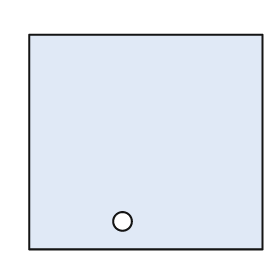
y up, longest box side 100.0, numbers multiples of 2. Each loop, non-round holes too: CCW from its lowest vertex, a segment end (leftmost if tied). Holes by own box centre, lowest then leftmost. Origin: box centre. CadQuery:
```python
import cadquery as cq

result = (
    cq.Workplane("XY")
    .moveTo(-50.0, -46.0)
    .lineTo(50.0, -46.0)
    .lineTo(50.0, 46.0)
    .lineTo(-50.0, 46.0)
    .close()
    .moveTo(-10.0, -34.0)
    .circle(4.0)
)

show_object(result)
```